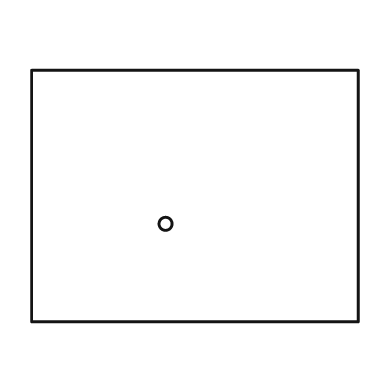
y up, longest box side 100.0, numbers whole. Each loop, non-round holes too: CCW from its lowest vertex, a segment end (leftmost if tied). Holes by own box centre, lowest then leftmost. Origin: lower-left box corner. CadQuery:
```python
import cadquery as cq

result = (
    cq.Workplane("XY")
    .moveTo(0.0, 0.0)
    .lineTo(100.0, 0.0)
    .lineTo(100.0, 77.0)
    .lineTo(0.0, 77.0)
    .close()
    .moveTo(41.0, 30.0)
    .circle(2.0)
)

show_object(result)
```